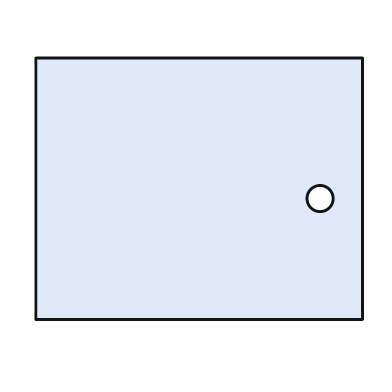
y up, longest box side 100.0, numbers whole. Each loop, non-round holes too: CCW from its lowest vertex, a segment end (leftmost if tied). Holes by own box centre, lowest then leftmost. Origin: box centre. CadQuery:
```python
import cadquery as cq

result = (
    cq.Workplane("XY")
    .moveTo(-50.0, -40.0)
    .lineTo(50.0, -40.0)
    .lineTo(50.0, 40.0)
    .lineTo(-50.0, 40.0)
    .close()
    .moveTo(37.0, -3.0)
    .circle(4.0)
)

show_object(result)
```